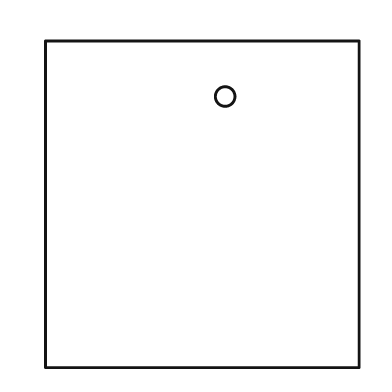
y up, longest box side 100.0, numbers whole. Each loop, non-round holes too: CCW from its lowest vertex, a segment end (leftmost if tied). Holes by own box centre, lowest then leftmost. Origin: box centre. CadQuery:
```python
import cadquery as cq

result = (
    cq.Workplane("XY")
    .moveTo(-48.0, -50.0)
    .lineTo(48.0, -50.0)
    .lineTo(48.0, 50.0)
    .lineTo(-48.0, 50.0)
    .close()
    .moveTo(7.0, 33.0)
    .circle(3.0)
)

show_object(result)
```